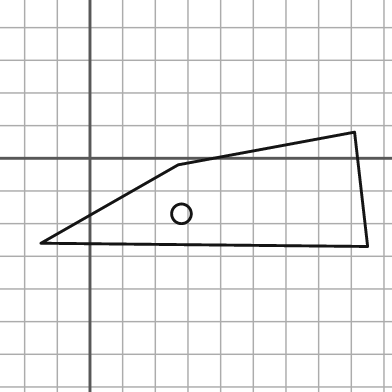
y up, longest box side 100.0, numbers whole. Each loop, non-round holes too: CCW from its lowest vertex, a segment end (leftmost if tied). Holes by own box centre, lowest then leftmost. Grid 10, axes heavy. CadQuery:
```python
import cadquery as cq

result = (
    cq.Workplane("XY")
    .moveTo(85.0, -27.0)
    .lineTo(81.0, 8.0)
    .lineTo(27.0, -2.0)
    .lineTo(-15.0, -26.0)
    .close()
    .moveTo(28.0, -17.0)
    .circle(3.0)
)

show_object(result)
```